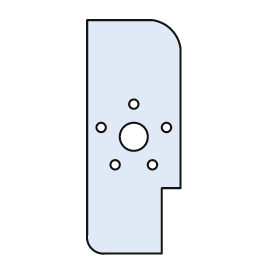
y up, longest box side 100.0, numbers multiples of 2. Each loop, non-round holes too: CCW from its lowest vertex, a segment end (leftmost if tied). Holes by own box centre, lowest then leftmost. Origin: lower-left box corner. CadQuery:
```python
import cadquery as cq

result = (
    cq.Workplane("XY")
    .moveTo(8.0, 0.0)
    .lineTo(32.0, 0.0)
    .lineTo(32.0, 28.0)
    .lineTo(40.0, 28.0)
    .lineTo(40.0, 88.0)
    .threePointArc((36.0, 96.0), (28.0, 100.0))
    .lineTo(0.0, 100.0)
    .lineTo(0.0, 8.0)
    .threePointArc((2.0, 2.0), (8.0, 0.0))
    .close()
    .moveTo(12.0, 38.0)
    .circle(2.0)
    .moveTo(28.0, 38.0)
    .circle(2.0)
    .moveTo(20.0, 50.0)
    .circle(6.0)
    .moveTo(6.0, 54.0)
    .circle(2.0)
    .moveTo(34.0, 54.0)
    .circle(2.0)
    .moveTo(20.0, 64.0)
    .circle(2.0)
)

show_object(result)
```